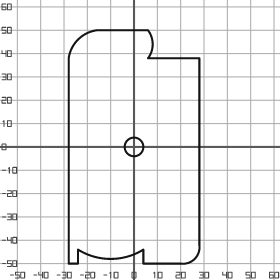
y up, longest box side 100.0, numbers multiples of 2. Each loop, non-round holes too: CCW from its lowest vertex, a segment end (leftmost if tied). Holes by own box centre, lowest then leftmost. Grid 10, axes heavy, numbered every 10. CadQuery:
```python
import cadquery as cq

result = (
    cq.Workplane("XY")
    .moveTo(-28.0, -50.0)
    .lineTo(-24.0, -50.0)
    .lineTo(-24.0, -44.0)
    .threePointArc((-10.0, -48.0), (4.0, -44.0))
    .lineTo(4.0, -50.0)
    .lineTo(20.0, -50.0)
    .threePointArc((26.0, -48.0), (28.0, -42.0))
    .lineTo(28.0, 38.0)
    .lineTo(6.0, 38.0)
    .threePointArc((8.0, 44.0), (6.0, 50.0))
    .lineTo(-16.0, 50.0)
    .threePointArc((-24.0, 46.0), (-28.0, 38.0))
    .close()
    .moveTo(0.0, 0.0)
    .circle(4.0)
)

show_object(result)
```